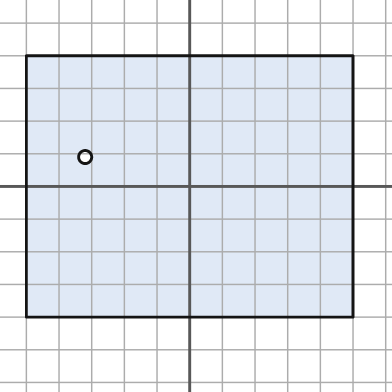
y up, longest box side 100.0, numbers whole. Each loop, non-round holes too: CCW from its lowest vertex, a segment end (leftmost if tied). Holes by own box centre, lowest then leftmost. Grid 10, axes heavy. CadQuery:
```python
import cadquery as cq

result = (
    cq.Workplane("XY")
    .moveTo(-50.0, -40.0)
    .lineTo(50.0, -40.0)
    .lineTo(50.0, 40.0)
    .lineTo(-50.0, 40.0)
    .close()
    .moveTo(-32.0, 9.0)
    .circle(2.0)
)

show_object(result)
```